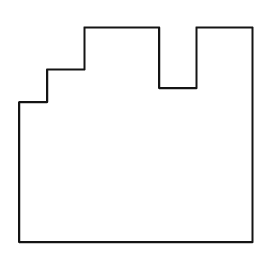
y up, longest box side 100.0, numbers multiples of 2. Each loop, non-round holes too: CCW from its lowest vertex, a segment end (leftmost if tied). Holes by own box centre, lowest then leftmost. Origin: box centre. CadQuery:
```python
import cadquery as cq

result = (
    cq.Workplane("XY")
    .moveTo(-50.0, -46.0)
    .lineTo(50.0, -46.0)
    .lineTo(50.0, 46.0)
    .lineTo(26.0, 46.0)
    .lineTo(26.0, 20.0)
    .lineTo(10.0, 20.0)
    .lineTo(10.0, 46.0)
    .lineTo(-22.0, 46.0)
    .lineTo(-22.0, 28.0)
    .lineTo(-38.0, 28.0)
    .lineTo(-38.0, 14.0)
    .lineTo(-50.0, 14.0)
    .close()
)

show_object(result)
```